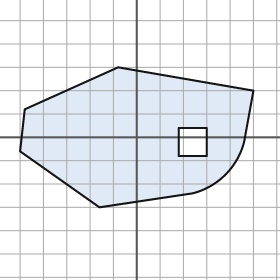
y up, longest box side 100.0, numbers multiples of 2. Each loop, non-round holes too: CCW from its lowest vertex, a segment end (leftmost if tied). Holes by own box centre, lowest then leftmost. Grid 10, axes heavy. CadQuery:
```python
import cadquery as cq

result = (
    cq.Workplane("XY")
    .moveTo(-16.0, -30.0)
    .lineTo(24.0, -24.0)
    .threePointArc((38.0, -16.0), (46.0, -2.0))
    .lineTo(50.0, 20.0)
    .lineTo(-8.0, 30.0)
    .lineTo(-48.0, 12.0)
    .lineTo(-50.0, -6.0)
    .close()
    .moveTo(18.0, -8.0)
    .lineTo(30.0, -8.0)
    .lineTo(30.0, 4.0)
    .lineTo(18.0, 4.0)
    .close()
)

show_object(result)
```